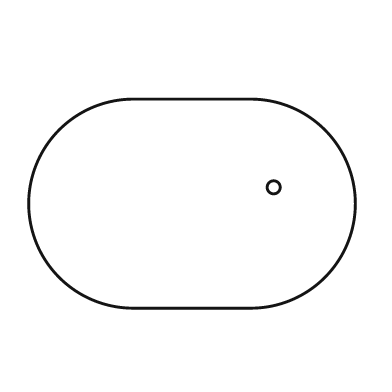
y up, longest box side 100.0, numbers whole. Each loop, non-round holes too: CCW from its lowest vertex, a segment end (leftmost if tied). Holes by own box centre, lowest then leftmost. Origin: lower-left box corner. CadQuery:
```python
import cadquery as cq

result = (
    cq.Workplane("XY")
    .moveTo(32.0, 0.0)
    .lineTo(68.0, 0.0)
    .threePointArc((100.0, 32.0), (68.0, 64.0))
    .lineTo(32.0, 64.0)
    .threePointArc((0.0, 32.0), (32.0, 0.0))
    .close()
    .moveTo(75.0, 37.0)
    .circle(2.0)
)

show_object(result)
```